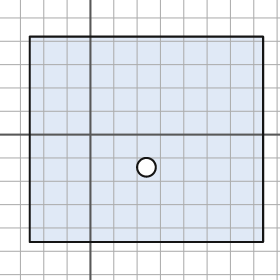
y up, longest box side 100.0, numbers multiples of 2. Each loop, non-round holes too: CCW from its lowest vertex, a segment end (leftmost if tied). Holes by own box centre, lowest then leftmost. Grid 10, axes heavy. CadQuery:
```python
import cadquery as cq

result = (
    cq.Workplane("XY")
    .moveTo(-26.0, -46.0)
    .lineTo(74.0, -46.0)
    .lineTo(74.0, 42.0)
    .lineTo(-26.0, 42.0)
    .close()
    .moveTo(24.0, -14.0)
    .circle(4.0)
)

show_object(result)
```